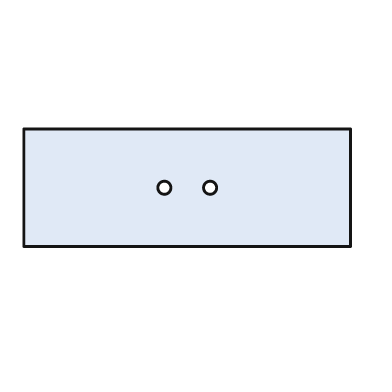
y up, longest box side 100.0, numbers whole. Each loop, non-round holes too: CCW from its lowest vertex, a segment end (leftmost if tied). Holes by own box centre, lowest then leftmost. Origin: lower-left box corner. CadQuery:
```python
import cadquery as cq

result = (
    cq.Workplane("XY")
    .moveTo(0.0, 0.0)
    .lineTo(100.0, 0.0)
    .lineTo(100.0, 36.0)
    .lineTo(0.0, 36.0)
    .close()
    .moveTo(43.0, 18.0)
    .circle(2.0)
    .moveTo(57.0, 18.0)
    .circle(2.0)
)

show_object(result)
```